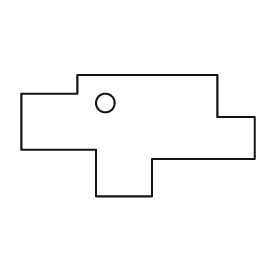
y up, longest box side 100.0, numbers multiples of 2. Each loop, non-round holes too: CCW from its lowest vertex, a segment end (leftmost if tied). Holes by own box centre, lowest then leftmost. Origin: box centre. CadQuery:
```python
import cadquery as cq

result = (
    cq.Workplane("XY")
    .moveTo(-18.0, -26.0)
    .lineTo(6.0, -26.0)
    .lineTo(6.0, -10.0)
    .lineTo(50.0, -10.0)
    .lineTo(50.0, 8.0)
    .lineTo(34.0, 8.0)
    .lineTo(34.0, 26.0)
    .lineTo(-26.0, 26.0)
    .lineTo(-26.0, 18.0)
    .lineTo(-50.0, 18.0)
    .lineTo(-50.0, -6.0)
    .lineTo(-18.0, -6.0)
    .close()
    .moveTo(-14.0, 14.0)
    .circle(4.0)
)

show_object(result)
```